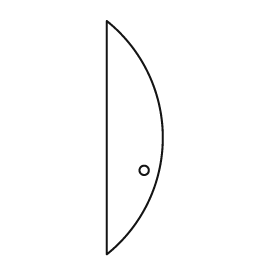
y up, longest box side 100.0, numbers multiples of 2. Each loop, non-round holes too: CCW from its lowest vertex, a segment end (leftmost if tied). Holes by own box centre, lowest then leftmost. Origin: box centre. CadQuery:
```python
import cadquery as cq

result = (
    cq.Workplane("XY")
    .moveTo(-12.0, -50.0)
    .threePointArc((12.0, 0.0), (-12.0, 50.0))
    .close()
    .moveTo(4.0, -14.0)
    .circle(2.0)
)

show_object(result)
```